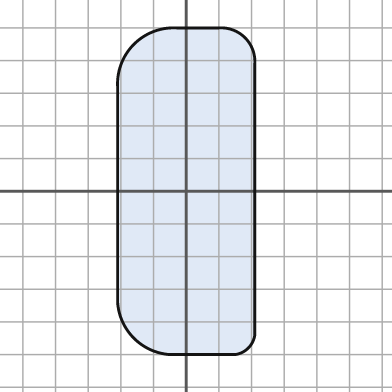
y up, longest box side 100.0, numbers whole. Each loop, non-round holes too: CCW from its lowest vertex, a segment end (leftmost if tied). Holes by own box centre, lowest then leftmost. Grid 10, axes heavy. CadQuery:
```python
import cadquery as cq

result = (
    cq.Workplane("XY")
    .moveTo(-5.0, -50.0)
    .lineTo(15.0, -50.0)
    .threePointArc((19.0, -48.0), (21.0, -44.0))
    .lineTo(21.0, 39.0)
    .threePointArc((18.0, 47.0), (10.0, 50.0))
    .lineTo(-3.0, 50.0)
    .threePointArc((-16.0, 45.0), (-21.0, 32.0))
    .lineTo(-21.0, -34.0)
    .threePointArc((-16.0, -45.0), (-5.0, -50.0))
    .close()
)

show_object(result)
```